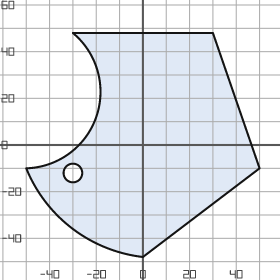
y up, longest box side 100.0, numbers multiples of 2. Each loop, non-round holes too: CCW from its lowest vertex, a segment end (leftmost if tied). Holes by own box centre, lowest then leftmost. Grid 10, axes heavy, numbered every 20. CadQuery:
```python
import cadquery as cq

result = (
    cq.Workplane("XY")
    .moveTo(0.0, -48.0)
    .lineTo(50.0, -10.0)
    .lineTo(30.0, 48.0)
    .lineTo(-30.0, 48.0)
    .threePointArc((-20.0, 12.0), (-50.0, -10.0))
    .threePointArc((-30.0, -36.0), (0.0, -48.0))
    .close()
    .moveTo(-30.0, -12.0)
    .circle(4.0)
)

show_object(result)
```